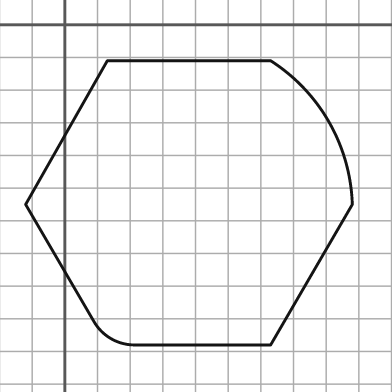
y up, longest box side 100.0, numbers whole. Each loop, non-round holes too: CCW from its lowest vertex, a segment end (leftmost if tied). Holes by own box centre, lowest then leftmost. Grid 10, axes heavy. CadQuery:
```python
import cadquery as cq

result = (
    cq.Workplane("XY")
    .moveTo(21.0, -98.0)
    .lineTo(63.0, -98.0)
    .lineTo(88.0, -55.0)
    .threePointArc((81.0, -30.0), (63.0, -11.0))
    .lineTo(13.0, -11.0)
    .lineTo(-12.0, -55.0)
    .lineTo(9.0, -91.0)
    .threePointArc((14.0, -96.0), (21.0, -98.0))
    .close()
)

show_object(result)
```